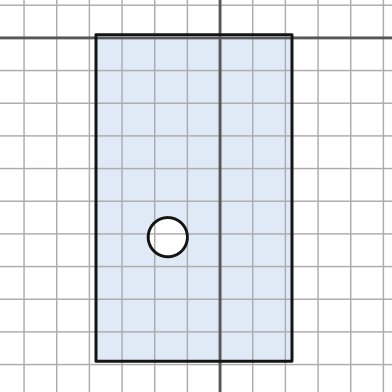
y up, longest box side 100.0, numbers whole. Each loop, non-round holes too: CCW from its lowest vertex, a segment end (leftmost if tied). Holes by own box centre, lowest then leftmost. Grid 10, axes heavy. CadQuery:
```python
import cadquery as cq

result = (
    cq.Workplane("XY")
    .moveTo(-38.0, -99.0)
    .lineTo(22.0, -99.0)
    .lineTo(22.0, 1.0)
    .lineTo(-38.0, 1.0)
    .close()
    .moveTo(-16.0, -61.0)
    .circle(6.0)
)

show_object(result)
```